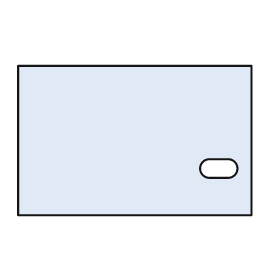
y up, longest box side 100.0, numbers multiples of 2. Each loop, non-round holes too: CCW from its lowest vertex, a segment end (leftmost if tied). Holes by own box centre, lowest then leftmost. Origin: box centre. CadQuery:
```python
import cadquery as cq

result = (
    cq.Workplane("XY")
    .moveTo(-50.0, -32.0)
    .lineTo(50.0, -32.0)
    .lineTo(50.0, 32.0)
    .lineTo(-50.0, 32.0)
    .close()
    .moveTo(32.0, -16.0)
    .lineTo(40.0, -16.0)
    .threePointArc((44.0, -12.0), (40.0, -8.0))
    .lineTo(32.0, -8.0)
    .threePointArc((28.0, -12.0), (32.0, -16.0))
    .close()
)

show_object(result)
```